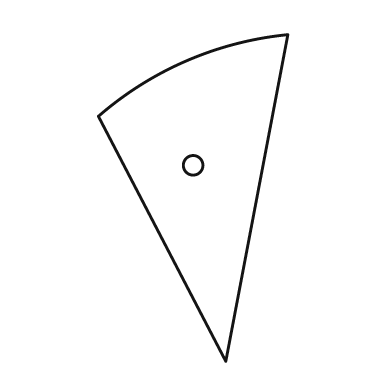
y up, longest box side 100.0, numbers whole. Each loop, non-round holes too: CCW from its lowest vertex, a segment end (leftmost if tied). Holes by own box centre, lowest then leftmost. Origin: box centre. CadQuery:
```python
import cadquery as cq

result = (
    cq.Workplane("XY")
    .moveTo(10.0, -50.0)
    .lineTo(29.0, 50.0)
    .threePointArc((-2.0, 42.0), (-29.0, 25.0))
    .close()
    .moveTo(0.0, 10.0)
    .circle(3.0)
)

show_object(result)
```